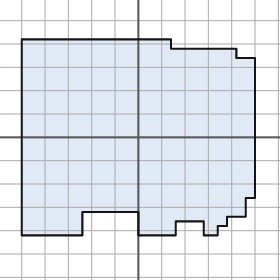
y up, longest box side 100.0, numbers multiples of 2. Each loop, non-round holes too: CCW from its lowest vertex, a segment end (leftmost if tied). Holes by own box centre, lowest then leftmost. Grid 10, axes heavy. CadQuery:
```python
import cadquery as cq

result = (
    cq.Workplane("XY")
    .moveTo(-50.0, -42.0)
    .lineTo(-24.0, -42.0)
    .lineTo(-24.0, -32.0)
    .lineTo(0.0, -32.0)
    .lineTo(0.0, -42.0)
    .lineTo(16.0, -42.0)
    .lineTo(16.0, -36.0)
    .lineTo(28.0, -36.0)
    .lineTo(28.0, -42.0)
    .lineTo(34.0, -42.0)
    .lineTo(34.0, -38.0)
    .lineTo(38.0, -38.0)
    .lineTo(38.0, -34.0)
    .lineTo(46.0, -34.0)
    .lineTo(46.0, -26.0)
    .lineTo(50.0, -26.0)
    .lineTo(50.0, 34.0)
    .lineTo(42.0, 34.0)
    .lineTo(42.0, 38.0)
    .lineTo(14.0, 38.0)
    .lineTo(14.0, 42.0)
    .lineTo(-50.0, 42.0)
    .close()
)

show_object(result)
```